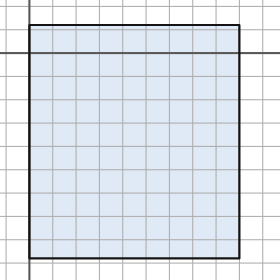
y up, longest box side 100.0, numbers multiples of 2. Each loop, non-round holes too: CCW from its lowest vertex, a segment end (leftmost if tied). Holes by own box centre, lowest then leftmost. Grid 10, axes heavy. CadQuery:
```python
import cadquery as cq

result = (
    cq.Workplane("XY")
    .moveTo(0.0, -88.0)
    .lineTo(90.0, -88.0)
    .lineTo(90.0, 12.0)
    .lineTo(0.0, 12.0)
    .close()
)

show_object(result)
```